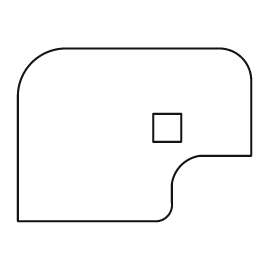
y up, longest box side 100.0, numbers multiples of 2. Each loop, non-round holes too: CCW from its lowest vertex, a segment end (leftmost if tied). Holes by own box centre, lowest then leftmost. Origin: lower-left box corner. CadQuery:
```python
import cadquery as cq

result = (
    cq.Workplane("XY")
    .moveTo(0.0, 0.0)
    .lineTo(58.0, 0.0)
    .threePointArc((64.0, 2.0), (66.0, 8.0))
    .lineTo(66.0, 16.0)
    .threePointArc((70.0, 24.0), (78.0, 28.0))
    .lineTo(100.0, 28.0)
    .lineTo(100.0, 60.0)
    .threePointArc((96.0, 70.0), (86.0, 74.0))
    .lineTo(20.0, 74.0)
    .threePointArc((6.0, 68.0), (0.0, 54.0))
    .close()
    .moveTo(58.0, 34.0)
    .lineTo(70.0, 34.0)
    .lineTo(70.0, 46.0)
    .lineTo(58.0, 46.0)
    .close()
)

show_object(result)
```